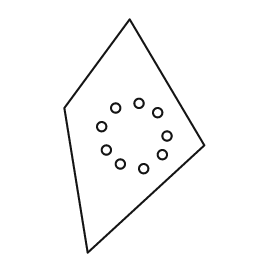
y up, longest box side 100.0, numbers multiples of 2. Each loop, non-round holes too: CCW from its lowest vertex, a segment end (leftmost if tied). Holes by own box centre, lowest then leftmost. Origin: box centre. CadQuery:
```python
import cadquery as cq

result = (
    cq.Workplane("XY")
    .moveTo(-20.0, -50.0)
    .lineTo(30.0, -4.0)
    .lineTo(-2.0, 50.0)
    .lineTo(-30.0, 12.0)
    .close()
    .moveTo(4.0, -14.0)
    .circle(2.0)
    .moveTo(-6.0, -12.0)
    .circle(2.0)
    .moveTo(12.0, -8.0)
    .circle(2.0)
    .moveTo(-12.0, -6.0)
    .circle(2.0)
    .moveTo(14.0, 0.0)
    .circle(2.0)
    .moveTo(-14.0, 4.0)
    .circle(2.0)
    .moveTo(10.0, 10.0)
    .circle(2.0)
    .moveTo(-8.0, 12.0)
    .circle(2.0)
    .moveTo(2.0, 14.0)
    .circle(2.0)
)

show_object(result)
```